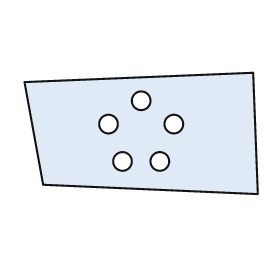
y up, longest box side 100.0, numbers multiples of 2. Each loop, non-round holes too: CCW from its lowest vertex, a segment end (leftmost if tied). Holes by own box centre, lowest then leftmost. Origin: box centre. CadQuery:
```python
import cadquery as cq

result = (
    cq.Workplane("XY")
    .moveTo(50.0, -26.0)
    .lineTo(48.0, 26.0)
    .lineTo(-50.0, 22.0)
    .lineTo(-42.0, -22.0)
    .close()
    .moveTo(-8.0, -12.0)
    .circle(4.0)
    .moveTo(8.0, -12.0)
    .circle(4.0)
    .moveTo(-14.0, 4.0)
    .circle(4.0)
    .moveTo(14.0, 4.0)
    .circle(4.0)
    .moveTo(0.0, 14.0)
    .circle(4.0)
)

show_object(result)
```